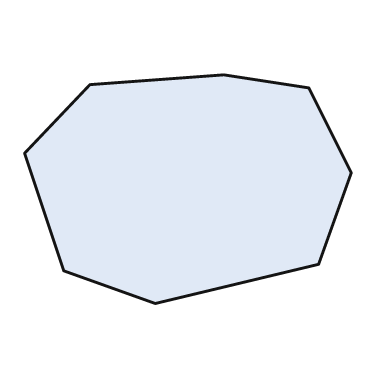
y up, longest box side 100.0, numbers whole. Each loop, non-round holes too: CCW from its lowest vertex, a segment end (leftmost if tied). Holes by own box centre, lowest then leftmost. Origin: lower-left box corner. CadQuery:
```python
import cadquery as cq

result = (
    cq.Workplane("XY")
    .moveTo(40.0, 0.0)
    .lineTo(90.0, 12.0)
    .lineTo(100.0, 40.0)
    .lineTo(87.0, 66.0)
    .lineTo(61.0, 70.0)
    .lineTo(20.0, 67.0)
    .lineTo(0.0, 46.0)
    .lineTo(12.0, 10.0)
    .close()
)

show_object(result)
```